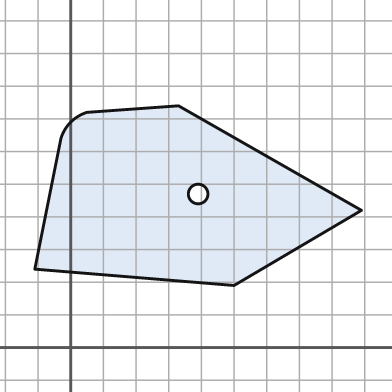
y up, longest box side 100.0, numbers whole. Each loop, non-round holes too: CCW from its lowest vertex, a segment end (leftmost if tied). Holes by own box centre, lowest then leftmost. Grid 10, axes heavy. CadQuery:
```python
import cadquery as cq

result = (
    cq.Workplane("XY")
    .moveTo(50.0, 19.0)
    .lineTo(89.0, 42.0)
    .lineTo(33.0, 74.0)
    .lineTo(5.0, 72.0)
    .threePointArc((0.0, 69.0), (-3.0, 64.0))
    .lineTo(-11.0, 24.0)
    .close()
    .moveTo(39.0, 47.0)
    .circle(3.0)
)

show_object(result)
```